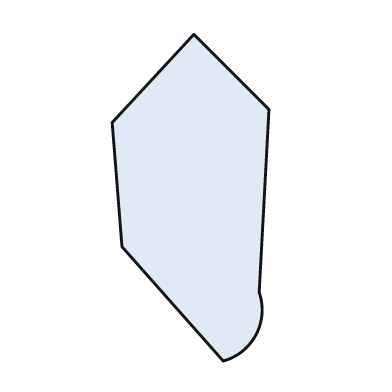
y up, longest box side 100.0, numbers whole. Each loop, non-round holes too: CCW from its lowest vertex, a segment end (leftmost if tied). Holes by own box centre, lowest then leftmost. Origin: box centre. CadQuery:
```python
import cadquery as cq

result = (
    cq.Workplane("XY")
    .moveTo(10.0, -50.0)
    .threePointArc((20.0, -42.0), (21.0, -29.0))
    .lineTo(24.0, 27.0)
    .lineTo(1.0, 50.0)
    .lineTo(-24.0, 23.0)
    .lineTo(-21.0, -15.0)
    .close()
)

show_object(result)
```